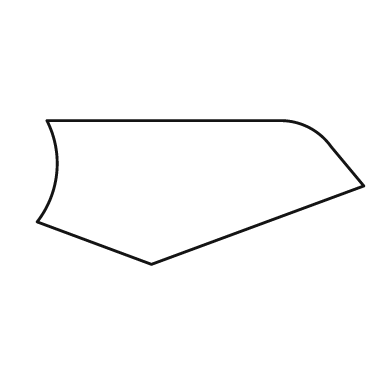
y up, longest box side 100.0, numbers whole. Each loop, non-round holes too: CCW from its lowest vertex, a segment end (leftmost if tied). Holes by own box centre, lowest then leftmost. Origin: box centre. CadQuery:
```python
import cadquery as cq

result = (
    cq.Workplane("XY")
    .moveTo(-15.0, -22.0)
    .lineTo(50.0, 2.0)
    .lineTo(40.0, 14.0)
    .threePointArc((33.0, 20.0), (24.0, 22.0))
    .lineTo(-47.0, 22.0)
    .threePointArc((-44.0, 6.0), (-50.0, -9.0))
    .close()
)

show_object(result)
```